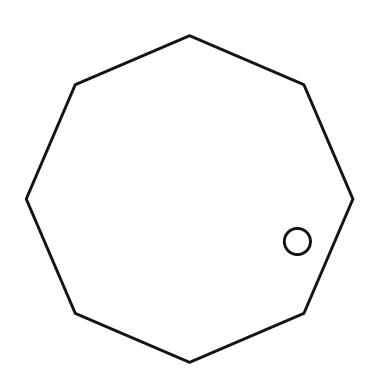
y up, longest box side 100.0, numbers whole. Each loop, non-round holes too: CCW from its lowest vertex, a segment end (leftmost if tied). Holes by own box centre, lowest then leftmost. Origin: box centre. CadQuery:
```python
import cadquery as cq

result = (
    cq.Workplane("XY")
    .moveTo(0.0, -50.0)
    .lineTo(35.0, -35.0)
    .lineTo(50.0, 0.0)
    .lineTo(35.0, 35.0)
    .lineTo(0.0, 50.0)
    .lineTo(-35.0, 35.0)
    .lineTo(-50.0, 0.0)
    .lineTo(-35.0, -35.0)
    .close()
    .moveTo(33.0, -13.0)
    .circle(4.0)
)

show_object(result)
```